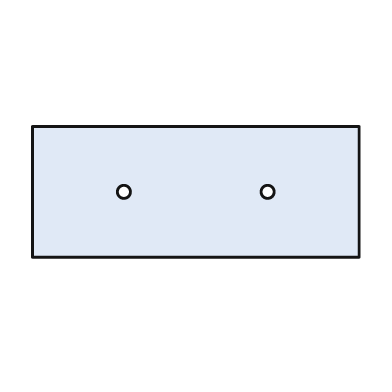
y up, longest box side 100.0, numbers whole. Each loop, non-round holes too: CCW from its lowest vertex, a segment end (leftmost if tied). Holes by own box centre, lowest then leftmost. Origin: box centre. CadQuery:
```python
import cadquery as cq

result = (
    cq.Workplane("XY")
    .moveTo(-50.0, -20.0)
    .lineTo(50.0, -20.0)
    .lineTo(50.0, 20.0)
    .lineTo(-50.0, 20.0)
    .close()
    .moveTo(-22.0, 0.0)
    .circle(2.0)
    .moveTo(22.0, 0.0)
    .circle(2.0)
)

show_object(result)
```